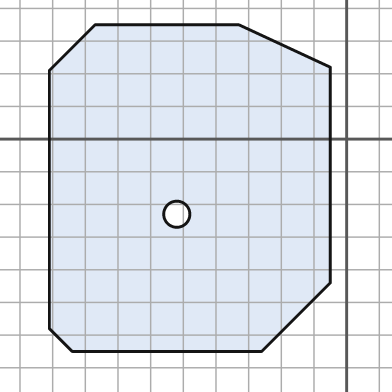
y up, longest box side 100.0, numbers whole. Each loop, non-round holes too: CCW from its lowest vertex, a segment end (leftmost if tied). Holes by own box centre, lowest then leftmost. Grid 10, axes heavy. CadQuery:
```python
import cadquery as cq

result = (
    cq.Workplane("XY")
    .moveTo(-84.0, -65.0)
    .lineTo(-26.0, -65.0)
    .lineTo(-5.0, -44.0)
    .lineTo(-5.0, 22.0)
    .lineTo(-33.0, 35.0)
    .lineTo(-77.0, 35.0)
    .lineTo(-91.0, 21.0)
    .lineTo(-91.0, -58.0)
    .close()
    .moveTo(-52.0, -23.0)
    .circle(4.0)
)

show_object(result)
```